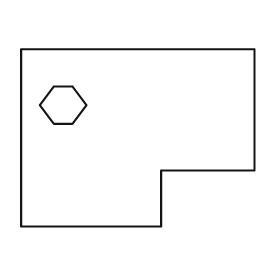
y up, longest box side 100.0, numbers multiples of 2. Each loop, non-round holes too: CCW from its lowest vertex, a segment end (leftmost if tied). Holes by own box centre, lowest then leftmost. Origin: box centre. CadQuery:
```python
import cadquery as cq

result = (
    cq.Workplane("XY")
    .moveTo(-50.0, -38.0)
    .lineTo(10.0, -38.0)
    .lineTo(10.0, -14.0)
    .lineTo(50.0, -14.0)
    .lineTo(50.0, 38.0)
    .lineTo(-50.0, 38.0)
    .close()
    .moveTo(-36.0, 6.0)
    .lineTo(-28.0, 6.0)
    .lineTo(-22.0, 14.0)
    .lineTo(-28.0, 22.0)
    .lineTo(-36.0, 22.0)
    .lineTo(-42.0, 14.0)
    .close()
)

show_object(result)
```